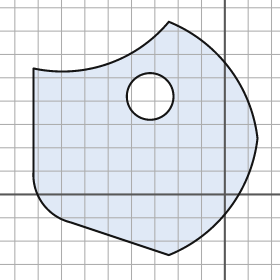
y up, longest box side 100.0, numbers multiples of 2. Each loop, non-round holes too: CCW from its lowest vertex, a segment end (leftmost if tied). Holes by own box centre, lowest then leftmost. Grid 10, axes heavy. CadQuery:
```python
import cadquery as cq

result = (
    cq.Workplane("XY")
    .moveTo(-24.0, -26.0)
    .threePointArc((2.0, -6.0), (14.0, 24.0))
    .threePointArc((2.0, 54.0), (-24.0, 74.0))
    .threePointArc((-50.0, 56.0), (-82.0, 54.0))
    .lineTo(-82.0, 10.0)
    .threePointArc((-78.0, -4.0), (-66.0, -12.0))
    .close()
    .moveTo(-32.0, 42.0)
    .circle(10.0)
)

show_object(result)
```